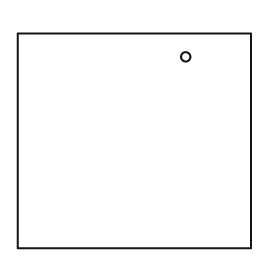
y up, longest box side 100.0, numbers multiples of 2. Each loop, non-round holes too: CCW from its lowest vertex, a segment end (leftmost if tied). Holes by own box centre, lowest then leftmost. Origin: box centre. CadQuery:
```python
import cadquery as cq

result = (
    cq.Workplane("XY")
    .moveTo(-50.0, -46.0)
    .lineTo(50.0, -46.0)
    .lineTo(50.0, 46.0)
    .lineTo(-50.0, 46.0)
    .close()
    .moveTo(22.0, 36.0)
    .circle(2.0)
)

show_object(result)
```